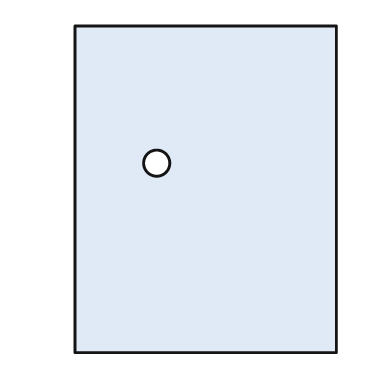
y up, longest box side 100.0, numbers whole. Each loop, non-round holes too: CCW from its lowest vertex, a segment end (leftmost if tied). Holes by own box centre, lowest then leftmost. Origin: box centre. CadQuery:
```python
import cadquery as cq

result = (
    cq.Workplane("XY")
    .moveTo(-40.0, -50.0)
    .lineTo(40.0, -50.0)
    .lineTo(40.0, 50.0)
    .lineTo(-40.0, 50.0)
    .close()
    .moveTo(-15.0, 8.0)
    .circle(4.0)
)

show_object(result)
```